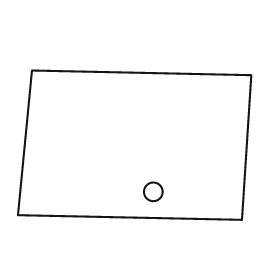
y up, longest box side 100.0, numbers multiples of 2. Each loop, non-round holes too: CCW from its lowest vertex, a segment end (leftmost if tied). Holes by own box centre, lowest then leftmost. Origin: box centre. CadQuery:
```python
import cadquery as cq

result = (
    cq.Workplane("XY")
    .moveTo(46.0, -32.0)
    .lineTo(50.0, 30.0)
    .lineTo(-44.0, 32.0)
    .lineTo(-50.0, -30.0)
    .close()
    .moveTo(8.0, -20.0)
    .circle(4.0)
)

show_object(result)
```